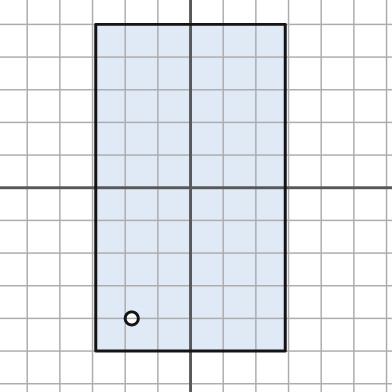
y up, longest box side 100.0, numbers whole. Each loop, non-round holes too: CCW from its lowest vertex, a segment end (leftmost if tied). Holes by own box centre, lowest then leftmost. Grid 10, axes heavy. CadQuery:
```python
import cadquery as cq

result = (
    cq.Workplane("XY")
    .moveTo(-29.0, -50.0)
    .lineTo(29.0, -50.0)
    .lineTo(29.0, 50.0)
    .lineTo(-29.0, 50.0)
    .close()
    .moveTo(-18.0, -40.0)
    .circle(2.0)
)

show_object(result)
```